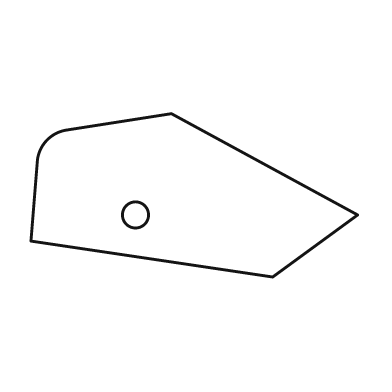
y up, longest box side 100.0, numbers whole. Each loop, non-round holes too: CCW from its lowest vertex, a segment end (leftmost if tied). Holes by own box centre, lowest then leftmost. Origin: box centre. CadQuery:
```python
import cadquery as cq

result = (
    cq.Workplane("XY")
    .moveTo(24.0, -25.0)
    .lineTo(50.0, -6.0)
    .lineTo(-7.0, 25.0)
    .lineTo(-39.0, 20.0)
    .threePointArc((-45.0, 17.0), (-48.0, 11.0))
    .lineTo(-50.0, -14.0)
    .close()
    .moveTo(-18.0, -6.0)
    .circle(4.0)
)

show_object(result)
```